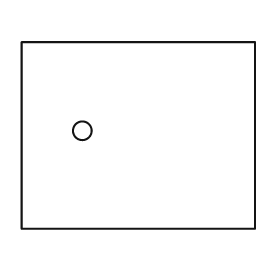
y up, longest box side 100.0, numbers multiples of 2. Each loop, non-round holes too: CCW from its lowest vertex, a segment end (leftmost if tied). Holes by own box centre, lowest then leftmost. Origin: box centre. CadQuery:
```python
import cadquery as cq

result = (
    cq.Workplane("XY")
    .moveTo(-50.0, -40.0)
    .lineTo(50.0, -40.0)
    .lineTo(50.0, 40.0)
    .lineTo(-50.0, 40.0)
    .close()
    .moveTo(-24.0, 2.0)
    .circle(4.0)
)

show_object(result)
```